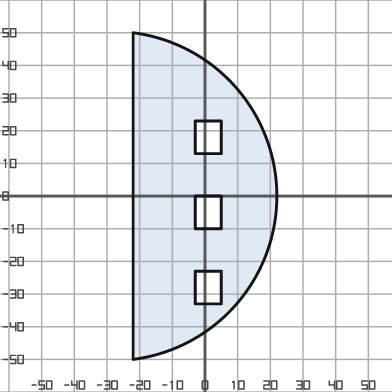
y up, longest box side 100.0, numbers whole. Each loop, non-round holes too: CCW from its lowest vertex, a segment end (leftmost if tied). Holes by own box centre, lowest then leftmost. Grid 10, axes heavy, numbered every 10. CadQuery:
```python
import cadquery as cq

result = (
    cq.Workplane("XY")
    .moveTo(-22.0, -50.0)
    .threePointArc((22.0, 0.0), (-22.0, 50.0))
    .close()
    .moveTo(-3.0, -33.0)
    .lineTo(5.0, -33.0)
    .lineTo(5.0, -23.0)
    .lineTo(-3.0, -23.0)
    .close()
    .moveTo(-3.0, -10.0)
    .lineTo(5.0, -10.0)
    .lineTo(5.0, 0.0)
    .lineTo(-3.0, 0.0)
    .close()
    .moveTo(-3.0, 13.0)
    .lineTo(5.0, 13.0)
    .lineTo(5.0, 23.0)
    .lineTo(-3.0, 23.0)
    .close()
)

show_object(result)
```